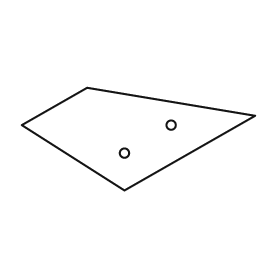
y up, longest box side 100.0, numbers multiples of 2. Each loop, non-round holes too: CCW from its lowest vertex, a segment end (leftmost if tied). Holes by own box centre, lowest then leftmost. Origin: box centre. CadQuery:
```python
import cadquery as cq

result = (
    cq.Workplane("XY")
    .moveTo(-6.0, -22.0)
    .lineTo(50.0, 10.0)
    .lineTo(-22.0, 22.0)
    .lineTo(-50.0, 6.0)
    .close()
    .moveTo(-6.0, -6.0)
    .circle(2.0)
    .moveTo(14.0, 6.0)
    .circle(2.0)
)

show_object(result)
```